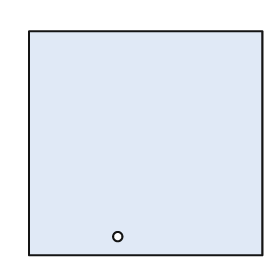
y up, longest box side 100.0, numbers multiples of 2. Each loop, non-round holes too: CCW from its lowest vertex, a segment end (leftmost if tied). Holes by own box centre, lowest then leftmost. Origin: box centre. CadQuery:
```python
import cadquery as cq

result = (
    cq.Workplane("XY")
    .moveTo(-50.0, -48.0)
    .lineTo(50.0, -48.0)
    .lineTo(50.0, 48.0)
    .lineTo(-50.0, 48.0)
    .close()
    .moveTo(-12.0, -40.0)
    .circle(2.0)
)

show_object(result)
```